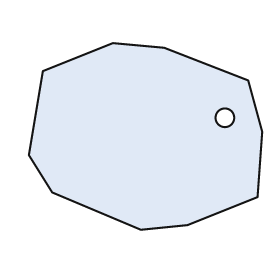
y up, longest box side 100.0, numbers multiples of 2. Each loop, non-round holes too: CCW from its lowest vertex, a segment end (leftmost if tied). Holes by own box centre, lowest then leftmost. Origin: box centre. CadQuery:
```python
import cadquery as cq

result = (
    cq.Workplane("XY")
    .moveTo(-2.0, -40.0)
    .lineTo(18.0, -38.0)
    .lineTo(48.0, -26.0)
    .lineTo(50.0, 2.0)
    .lineTo(44.0, 24.0)
    .lineTo(8.0, 38.0)
    .lineTo(-14.0, 40.0)
    .lineTo(-44.0, 28.0)
    .lineTo(-50.0, -8.0)
    .lineTo(-40.0, -24.0)
    .close()
    .moveTo(34.0, 8.0)
    .circle(4.0)
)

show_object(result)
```